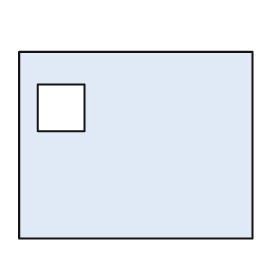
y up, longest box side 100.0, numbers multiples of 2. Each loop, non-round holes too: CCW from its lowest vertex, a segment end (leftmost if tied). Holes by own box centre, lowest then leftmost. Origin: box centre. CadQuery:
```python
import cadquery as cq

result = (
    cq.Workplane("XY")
    .moveTo(-50.0, -40.0)
    .lineTo(50.0, -40.0)
    .lineTo(50.0, 40.0)
    .lineTo(-50.0, 40.0)
    .close()
    .moveTo(-42.0, 6.0)
    .lineTo(-22.0, 6.0)
    .lineTo(-22.0, 26.0)
    .lineTo(-42.0, 26.0)
    .close()
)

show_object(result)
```